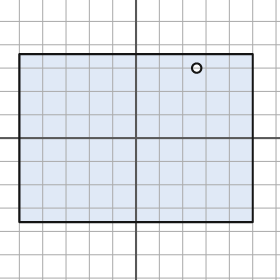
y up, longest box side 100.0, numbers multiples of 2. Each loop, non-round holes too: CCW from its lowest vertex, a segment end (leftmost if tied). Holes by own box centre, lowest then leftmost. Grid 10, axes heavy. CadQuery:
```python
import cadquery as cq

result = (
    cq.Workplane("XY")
    .moveTo(-50.0, -36.0)
    .lineTo(50.0, -36.0)
    .lineTo(50.0, 36.0)
    .lineTo(-50.0, 36.0)
    .close()
    .moveTo(26.0, 30.0)
    .circle(2.0)
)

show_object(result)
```